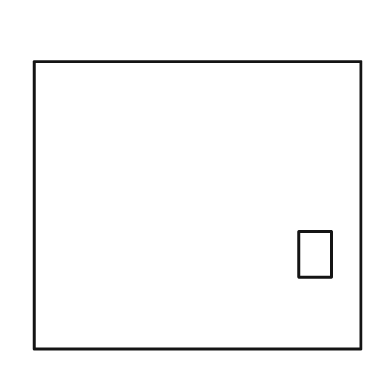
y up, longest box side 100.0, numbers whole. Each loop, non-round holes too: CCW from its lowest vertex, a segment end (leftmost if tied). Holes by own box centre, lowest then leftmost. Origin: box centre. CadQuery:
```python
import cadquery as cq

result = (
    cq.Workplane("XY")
    .moveTo(-50.0, -44.0)
    .lineTo(50.0, -44.0)
    .lineTo(50.0, 44.0)
    .lineTo(-50.0, 44.0)
    .close()
    .moveTo(31.0, -22.0)
    .lineTo(41.0, -22.0)
    .lineTo(41.0, -8.0)
    .lineTo(31.0, -8.0)
    .close()
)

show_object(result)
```